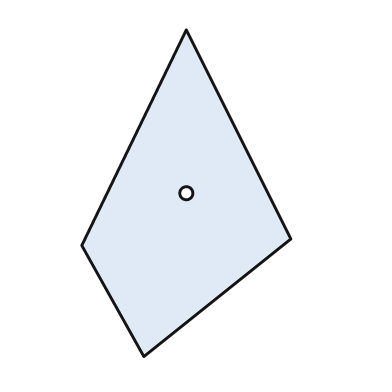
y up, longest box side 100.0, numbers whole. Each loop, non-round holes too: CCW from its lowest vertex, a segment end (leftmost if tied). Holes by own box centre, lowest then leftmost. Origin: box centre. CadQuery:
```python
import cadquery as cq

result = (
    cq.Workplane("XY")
    .moveTo(-13.0, -50.0)
    .lineTo(32.0, -14.0)
    .lineTo(0.0, 50.0)
    .lineTo(-32.0, -16.0)
    .close()
    .moveTo(0.0, 0.0)
    .circle(2.0)
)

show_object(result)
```